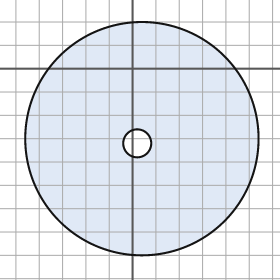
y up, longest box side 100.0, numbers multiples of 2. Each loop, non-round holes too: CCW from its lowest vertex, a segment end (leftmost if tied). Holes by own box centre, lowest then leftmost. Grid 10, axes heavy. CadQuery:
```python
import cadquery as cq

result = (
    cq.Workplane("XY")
    .moveTo(4.0, -30.0)
    .circle(50.0)
    .moveTo(2.0, -32.0)
    .circle(6.0)
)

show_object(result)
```